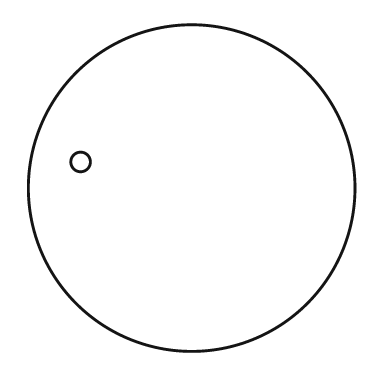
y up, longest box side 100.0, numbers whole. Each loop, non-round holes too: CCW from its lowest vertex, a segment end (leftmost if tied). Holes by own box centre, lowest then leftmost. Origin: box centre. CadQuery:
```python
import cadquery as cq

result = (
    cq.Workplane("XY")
    .moveTo(0.0, 0.0)
    .circle(50.0)
    .moveTo(-34.0, 8.0)
    .circle(3.0)
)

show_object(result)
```